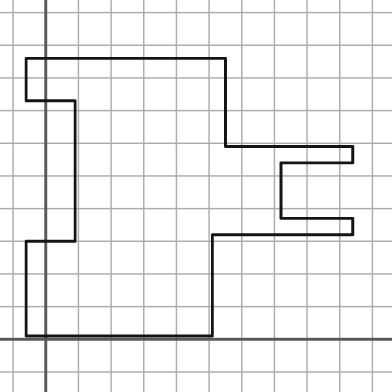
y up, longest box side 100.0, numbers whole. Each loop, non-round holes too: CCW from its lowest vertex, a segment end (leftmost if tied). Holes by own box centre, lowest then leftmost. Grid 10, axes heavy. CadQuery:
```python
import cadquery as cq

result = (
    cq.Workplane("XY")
    .moveTo(-6.0, 1.0)
    .lineTo(51.0, 1.0)
    .lineTo(51.0, 32.0)
    .lineTo(94.0, 32.0)
    .lineTo(94.0, 37.0)
    .lineTo(72.0, 37.0)
    .lineTo(72.0, 54.0)
    .lineTo(94.0, 54.0)
    .lineTo(94.0, 59.0)
    .lineTo(55.0, 59.0)
    .lineTo(55.0, 86.0)
    .lineTo(-6.0, 86.0)
    .lineTo(-6.0, 73.0)
    .lineTo(9.0, 73.0)
    .lineTo(9.0, 30.0)
    .lineTo(-6.0, 30.0)
    .close()
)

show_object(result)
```